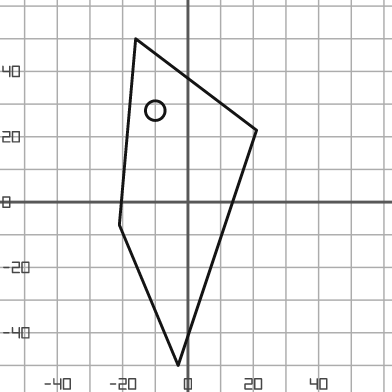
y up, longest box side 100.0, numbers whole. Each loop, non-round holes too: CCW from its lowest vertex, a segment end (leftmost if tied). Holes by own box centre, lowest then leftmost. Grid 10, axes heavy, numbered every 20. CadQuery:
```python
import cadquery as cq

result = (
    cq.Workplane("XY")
    .moveTo(-3.0, -50.0)
    .lineTo(21.0, 22.0)
    .lineTo(-16.0, 50.0)
    .lineTo(-21.0, -7.0)
    .close()
    .moveTo(-10.0, 28.0)
    .circle(3.0)
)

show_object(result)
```